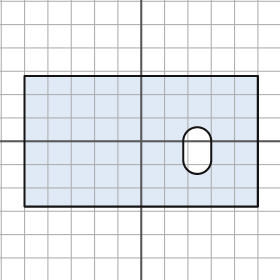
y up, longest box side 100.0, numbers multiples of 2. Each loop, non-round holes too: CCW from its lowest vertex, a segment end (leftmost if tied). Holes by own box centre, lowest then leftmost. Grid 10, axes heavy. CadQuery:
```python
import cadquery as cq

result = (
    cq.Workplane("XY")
    .moveTo(-50.0, -28.0)
    .lineTo(50.0, -28.0)
    .lineTo(50.0, 28.0)
    .lineTo(-50.0, 28.0)
    .close()
    .moveTo(18.0, -8.0)
    .threePointArc((24.0, -14.0), (30.0, -8.0))
    .lineTo(30.0, 0.0)
    .threePointArc((24.0, 6.0), (18.0, 0.0))
    .close()
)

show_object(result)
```